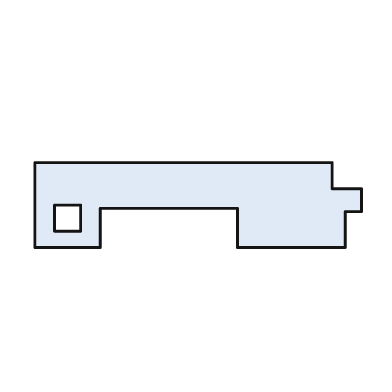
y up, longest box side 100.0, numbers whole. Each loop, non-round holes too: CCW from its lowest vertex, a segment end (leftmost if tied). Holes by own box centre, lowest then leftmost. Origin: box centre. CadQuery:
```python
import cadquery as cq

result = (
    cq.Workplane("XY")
    .moveTo(-50.0, -13.0)
    .lineTo(-30.0, -13.0)
    .lineTo(-30.0, -1.0)
    .lineTo(12.0, -1.0)
    .lineTo(12.0, -13.0)
    .lineTo(45.0, -13.0)
    .lineTo(45.0, -2.0)
    .lineTo(50.0, -2.0)
    .lineTo(50.0, 5.0)
    .lineTo(41.0, 5.0)
    .lineTo(41.0, 13.0)
    .lineTo(-50.0, 13.0)
    .close()
    .moveTo(-44.0, -8.0)
    .lineTo(-36.0, -8.0)
    .lineTo(-36.0, 0.0)
    .lineTo(-44.0, 0.0)
    .close()
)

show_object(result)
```